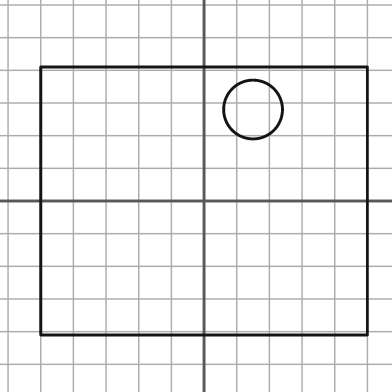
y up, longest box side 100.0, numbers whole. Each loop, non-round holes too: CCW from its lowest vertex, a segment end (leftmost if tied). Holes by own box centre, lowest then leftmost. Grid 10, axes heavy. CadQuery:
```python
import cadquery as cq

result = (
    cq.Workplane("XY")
    .moveTo(-50.0, -41.0)
    .lineTo(50.0, -41.0)
    .lineTo(50.0, 41.0)
    .lineTo(-50.0, 41.0)
    .close()
    .moveTo(15.0, 28.0)
    .circle(9.0)
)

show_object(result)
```